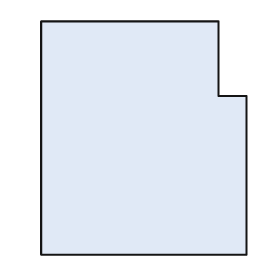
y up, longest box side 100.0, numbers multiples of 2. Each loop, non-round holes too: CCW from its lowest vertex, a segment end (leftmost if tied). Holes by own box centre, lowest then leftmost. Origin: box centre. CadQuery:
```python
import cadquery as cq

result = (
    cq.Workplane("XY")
    .moveTo(-44.0, -50.0)
    .lineTo(44.0, -50.0)
    .lineTo(44.0, 18.0)
    .lineTo(32.0, 18.0)
    .lineTo(32.0, 50.0)
    .lineTo(-44.0, 50.0)
    .close()
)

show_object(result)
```